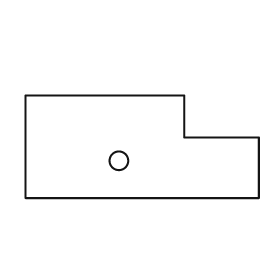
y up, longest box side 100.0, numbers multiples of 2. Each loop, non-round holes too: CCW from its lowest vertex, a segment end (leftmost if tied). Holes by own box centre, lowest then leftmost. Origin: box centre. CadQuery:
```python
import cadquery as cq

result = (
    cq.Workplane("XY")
    .moveTo(-50.0, -22.0)
    .lineTo(50.0, -22.0)
    .lineTo(50.0, 4.0)
    .lineTo(18.0, 4.0)
    .lineTo(18.0, 22.0)
    .lineTo(-50.0, 22.0)
    .close()
    .moveTo(-10.0, -6.0)
    .circle(4.0)
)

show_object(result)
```